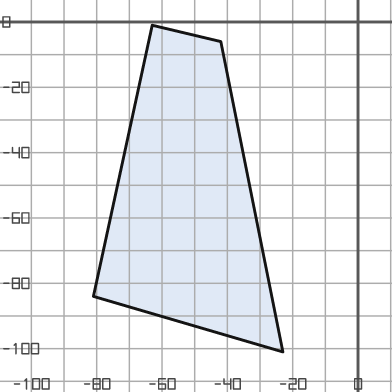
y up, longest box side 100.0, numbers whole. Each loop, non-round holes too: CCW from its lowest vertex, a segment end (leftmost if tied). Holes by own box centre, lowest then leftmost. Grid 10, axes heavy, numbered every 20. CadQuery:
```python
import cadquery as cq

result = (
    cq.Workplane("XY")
    .moveTo(-23.0, -101.0)
    .lineTo(-42.0, -6.0)
    .lineTo(-63.0, -1.0)
    .lineTo(-81.0, -84.0)
    .close()
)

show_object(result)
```